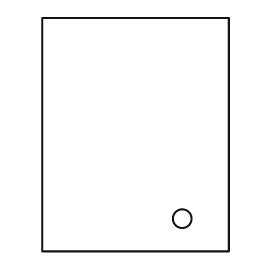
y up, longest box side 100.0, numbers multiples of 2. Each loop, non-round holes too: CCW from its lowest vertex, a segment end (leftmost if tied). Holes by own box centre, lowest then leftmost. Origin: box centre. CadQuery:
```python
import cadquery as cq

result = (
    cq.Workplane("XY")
    .moveTo(-40.0, -50.0)
    .lineTo(40.0, -50.0)
    .lineTo(40.0, 50.0)
    .lineTo(-40.0, 50.0)
    .close()
    .moveTo(20.0, -36.0)
    .circle(4.0)
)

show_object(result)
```